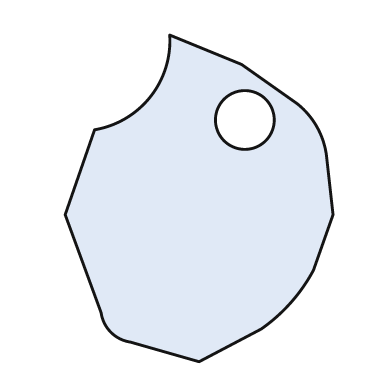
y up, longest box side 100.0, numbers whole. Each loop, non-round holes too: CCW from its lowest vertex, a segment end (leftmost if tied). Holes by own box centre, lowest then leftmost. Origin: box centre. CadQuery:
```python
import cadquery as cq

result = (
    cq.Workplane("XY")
    .moveTo(0.0, -50.0)
    .lineTo(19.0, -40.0)
    .threePointArc((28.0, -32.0), (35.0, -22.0))
    .lineTo(41.0, -5.0)
    .lineTo(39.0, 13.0)
    .threePointArc((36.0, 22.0), (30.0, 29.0))
    .lineTo(13.0, 41.0)
    .lineTo(-9.0, 50.0)
    .threePointArc((-15.0, 31.0), (-32.0, 21.0))
    .lineTo(-41.0, -5.0)
    .lineTo(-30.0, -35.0)
    .threePointArc((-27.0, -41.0), (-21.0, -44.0))
    .close()
    .moveTo(14.0, 24.0)
    .circle(9.0)
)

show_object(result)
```